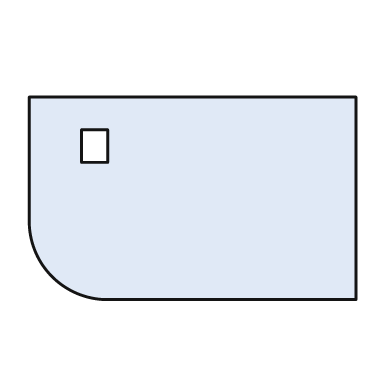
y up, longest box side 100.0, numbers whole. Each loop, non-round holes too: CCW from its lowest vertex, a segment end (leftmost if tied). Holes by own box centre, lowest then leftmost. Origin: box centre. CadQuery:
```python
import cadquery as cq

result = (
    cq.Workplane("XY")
    .moveTo(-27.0, -31.0)
    .lineTo(50.0, -31.0)
    .lineTo(50.0, 31.0)
    .lineTo(-50.0, 31.0)
    .lineTo(-50.0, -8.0)
    .threePointArc((-43.0, -24.0), (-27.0, -31.0))
    .close()
    .moveTo(-34.0, 11.0)
    .lineTo(-26.0, 11.0)
    .lineTo(-26.0, 21.0)
    .lineTo(-34.0, 21.0)
    .close()
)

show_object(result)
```